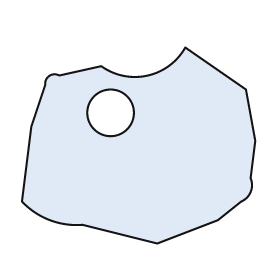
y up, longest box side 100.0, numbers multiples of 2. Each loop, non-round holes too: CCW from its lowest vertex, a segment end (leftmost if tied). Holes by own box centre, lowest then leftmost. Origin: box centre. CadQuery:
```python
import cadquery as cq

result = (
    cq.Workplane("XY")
    .moveTo(8.0, -42.0)
    .lineTo(34.0, -32.0)
    .lineTo(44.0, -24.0)
    .threePointArc((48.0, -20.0), (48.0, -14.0))
    .lineTo(50.0, 2.0)
    .lineTo(46.0, 24.0)
    .lineTo(20.0, 42.0)
    .threePointArc((4.0, 30.0), (-16.0, 34.0))
    .lineTo(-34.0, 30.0)
    .threePointArc((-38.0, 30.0), (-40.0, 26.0))
    .lineTo(-46.0, 8.0)
    .lineTo(-50.0, -24.0)
    .threePointArc((-38.0, -32.0), (-24.0, -34.0))
    .close()
    .moveTo(-12.0, 14.0)
    .circle(10.0)
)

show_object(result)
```